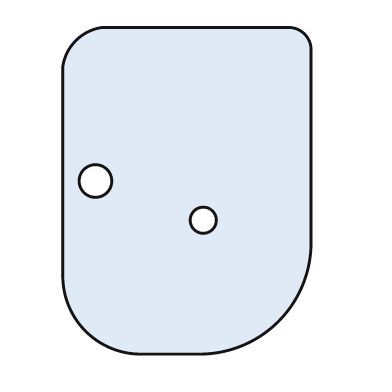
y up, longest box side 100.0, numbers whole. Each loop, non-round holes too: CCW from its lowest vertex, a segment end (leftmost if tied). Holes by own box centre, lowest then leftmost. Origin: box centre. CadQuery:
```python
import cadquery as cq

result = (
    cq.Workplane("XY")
    .moveTo(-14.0, -50.0)
    .lineTo(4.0, -50.0)
    .threePointArc((28.0, -40.0), (38.0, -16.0))
    .lineTo(38.0, 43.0)
    .threePointArc((36.0, 48.0), (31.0, 50.0))
    .lineTo(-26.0, 50.0)
    .threePointArc((-34.0, 46.0), (-38.0, 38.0))
    .lineTo(-38.0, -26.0)
    .threePointArc((-31.0, -43.0), (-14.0, -50.0))
    .close()
    .moveTo(5.0, -9.0)
    .circle(4.0)
    .moveTo(-28.0, 3.0)
    .circle(5.0)
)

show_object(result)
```